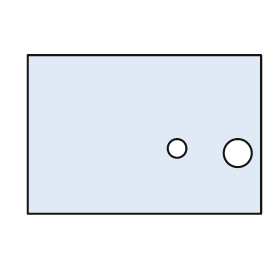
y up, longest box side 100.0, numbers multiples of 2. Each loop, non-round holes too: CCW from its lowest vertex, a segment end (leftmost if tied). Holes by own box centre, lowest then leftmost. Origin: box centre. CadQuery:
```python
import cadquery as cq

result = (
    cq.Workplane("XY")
    .moveTo(-50.0, -34.0)
    .lineTo(50.0, -34.0)
    .lineTo(50.0, 34.0)
    .lineTo(-50.0, 34.0)
    .close()
    .moveTo(40.0, -8.0)
    .circle(6.0)
    .moveTo(14.0, -6.0)
    .circle(4.0)
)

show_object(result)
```